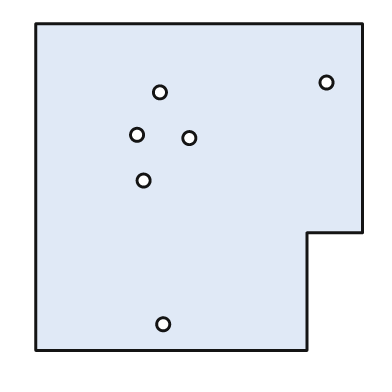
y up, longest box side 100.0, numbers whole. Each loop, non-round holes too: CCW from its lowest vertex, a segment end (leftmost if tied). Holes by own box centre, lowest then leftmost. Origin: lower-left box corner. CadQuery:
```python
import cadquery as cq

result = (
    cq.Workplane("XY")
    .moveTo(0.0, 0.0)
    .lineTo(83.0, 0.0)
    .lineTo(83.0, 36.0)
    .lineTo(100.0, 36.0)
    .lineTo(100.0, 100.0)
    .lineTo(0.0, 100.0)
    .close()
    .moveTo(39.0, 8.0)
    .circle(2.0)
    .moveTo(33.0, 52.0)
    .circle(2.0)
    .moveTo(47.0, 65.0)
    .circle(2.0)
    .moveTo(31.0, 66.0)
    .circle(2.0)
    .moveTo(38.0, 79.0)
    .circle(2.0)
    .moveTo(89.0, 82.0)
    .circle(2.0)
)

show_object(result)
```